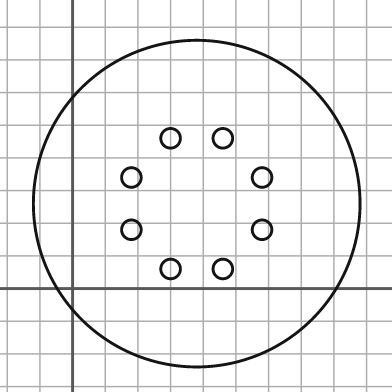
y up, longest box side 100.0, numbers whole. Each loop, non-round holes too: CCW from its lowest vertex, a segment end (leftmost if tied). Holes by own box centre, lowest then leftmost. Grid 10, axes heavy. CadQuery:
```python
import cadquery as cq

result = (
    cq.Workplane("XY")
    .moveTo(38.0, 26.0)
    .circle(50.0)
    .moveTo(30.0, 6.0)
    .circle(3.0)
    .moveTo(46.0, 6.0)
    .circle(3.0)
    .moveTo(18.0, 18.0)
    .circle(3.0)
    .moveTo(58.0, 18.0)
    .circle(3.0)
    .moveTo(18.0, 34.0)
    .circle(3.0)
    .moveTo(58.0, 34.0)
    .circle(3.0)
    .moveTo(30.0, 46.0)
    .circle(3.0)
    .moveTo(46.0, 46.0)
    .circle(3.0)
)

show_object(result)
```